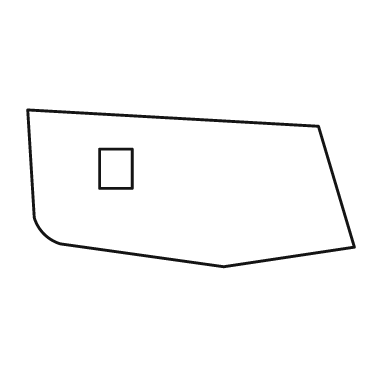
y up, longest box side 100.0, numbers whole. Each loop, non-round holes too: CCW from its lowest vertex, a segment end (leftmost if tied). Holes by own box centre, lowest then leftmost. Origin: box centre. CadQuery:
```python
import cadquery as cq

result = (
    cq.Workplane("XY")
    .moveTo(10.0, -24.0)
    .lineTo(50.0, -18.0)
    .lineTo(39.0, 19.0)
    .lineTo(-50.0, 24.0)
    .lineTo(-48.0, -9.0)
    .threePointArc((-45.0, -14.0), (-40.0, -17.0))
    .close()
    .moveTo(-28.0, 0.0)
    .lineTo(-18.0, 0.0)
    .lineTo(-18.0, 12.0)
    .lineTo(-28.0, 12.0)
    .close()
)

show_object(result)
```